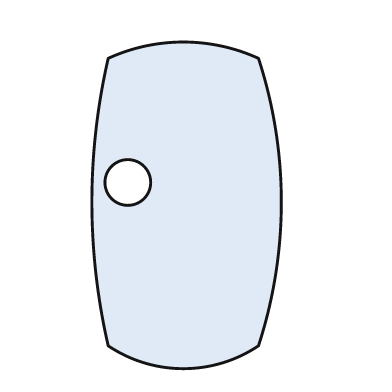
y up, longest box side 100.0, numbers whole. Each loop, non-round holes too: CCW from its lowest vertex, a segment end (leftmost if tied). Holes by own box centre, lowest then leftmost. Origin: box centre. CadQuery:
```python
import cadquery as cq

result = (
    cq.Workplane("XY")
    .moveTo(-24.0, -43.0)
    .threePointArc((-1.0, -50.0), (22.0, -43.0))
    .threePointArc((29.0, 1.0), (22.0, 45.0))
    .threePointArc((-1.0, 50.0), (-24.0, 45.0))
    .threePointArc((-29.0, 1.0), (-24.0, -43.0))
    .close()
    .moveTo(-18.0, 7.0)
    .circle(7.0)
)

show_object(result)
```